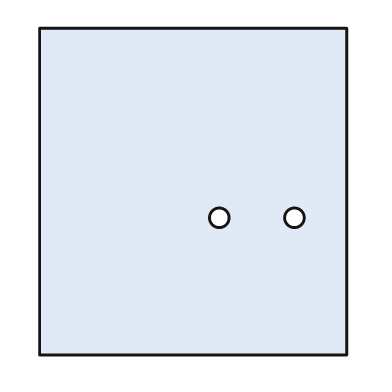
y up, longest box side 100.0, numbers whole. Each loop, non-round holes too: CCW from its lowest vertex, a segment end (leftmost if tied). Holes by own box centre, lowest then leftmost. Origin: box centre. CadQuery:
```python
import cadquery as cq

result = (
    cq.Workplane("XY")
    .moveTo(-47.0, -50.0)
    .lineTo(47.0, -50.0)
    .lineTo(47.0, 50.0)
    .lineTo(-47.0, 50.0)
    .close()
    .moveTo(8.0, -8.0)
    .circle(3.0)
    .moveTo(31.0, -8.0)
    .circle(3.0)
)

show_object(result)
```